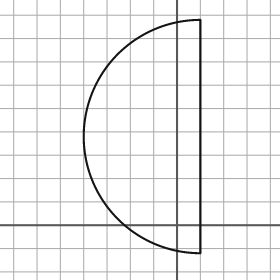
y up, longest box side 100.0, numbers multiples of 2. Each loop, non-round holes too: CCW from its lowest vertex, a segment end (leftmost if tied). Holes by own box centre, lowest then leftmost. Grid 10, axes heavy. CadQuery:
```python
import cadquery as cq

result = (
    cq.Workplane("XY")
    .moveTo(10.0, -12.0)
    .lineTo(10.0, 88.0)
    .threePointArc((-40.0, 38.0), (10.0, -12.0))
    .close()
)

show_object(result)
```